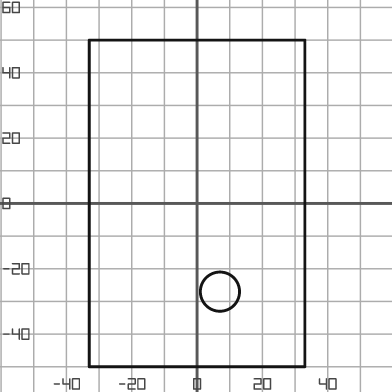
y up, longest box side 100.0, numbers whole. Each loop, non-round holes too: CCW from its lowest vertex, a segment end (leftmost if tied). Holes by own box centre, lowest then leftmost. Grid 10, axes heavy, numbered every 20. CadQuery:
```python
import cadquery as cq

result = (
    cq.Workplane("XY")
    .moveTo(-33.0, -50.0)
    .lineTo(33.0, -50.0)
    .lineTo(33.0, 50.0)
    .lineTo(-33.0, 50.0)
    .close()
    .moveTo(7.0, -27.0)
    .circle(6.0)
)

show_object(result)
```